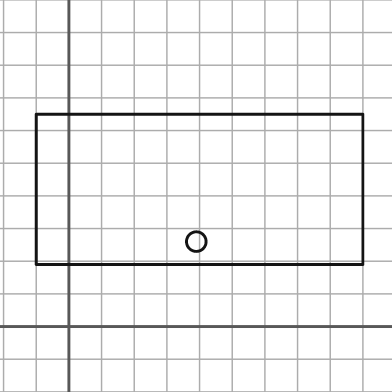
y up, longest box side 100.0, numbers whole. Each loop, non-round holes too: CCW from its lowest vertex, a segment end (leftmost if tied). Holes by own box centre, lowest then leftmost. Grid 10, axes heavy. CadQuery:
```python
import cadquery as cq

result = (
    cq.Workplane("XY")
    .moveTo(-10.0, 19.0)
    .lineTo(90.0, 19.0)
    .lineTo(90.0, 65.0)
    .lineTo(-10.0, 65.0)
    .close()
    .moveTo(39.0, 26.0)
    .circle(3.0)
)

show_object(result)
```